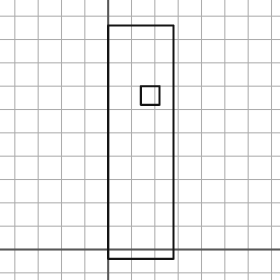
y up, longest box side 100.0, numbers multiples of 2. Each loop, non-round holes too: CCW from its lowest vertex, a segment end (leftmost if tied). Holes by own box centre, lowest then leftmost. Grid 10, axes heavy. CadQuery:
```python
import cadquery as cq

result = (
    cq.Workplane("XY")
    .moveTo(0.0, -4.0)
    .lineTo(28.0, -4.0)
    .lineTo(28.0, 96.0)
    .lineTo(0.0, 96.0)
    .close()
    .moveTo(14.0, 62.0)
    .lineTo(22.0, 62.0)
    .lineTo(22.0, 70.0)
    .lineTo(14.0, 70.0)
    .close()
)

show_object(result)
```